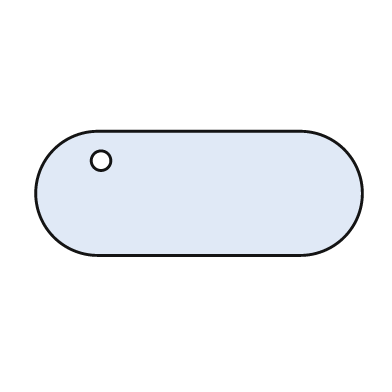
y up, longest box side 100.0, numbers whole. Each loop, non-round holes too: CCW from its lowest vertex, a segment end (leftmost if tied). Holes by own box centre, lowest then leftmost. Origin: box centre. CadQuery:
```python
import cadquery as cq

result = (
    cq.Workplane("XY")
    .moveTo(-31.0, -19.0)
    .lineTo(31.0, -19.0)
    .threePointArc((50.0, 0.0), (31.0, 19.0))
    .lineTo(-31.0, 19.0)
    .threePointArc((-50.0, 0.0), (-31.0, -19.0))
    .close()
    .moveTo(-30.0, 10.0)
    .circle(3.0)
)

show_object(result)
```